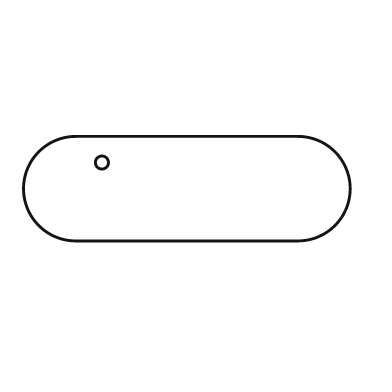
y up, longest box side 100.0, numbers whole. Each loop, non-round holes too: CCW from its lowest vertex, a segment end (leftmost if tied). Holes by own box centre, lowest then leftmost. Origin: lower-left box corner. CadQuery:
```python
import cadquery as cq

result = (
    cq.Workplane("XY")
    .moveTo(16.0, 0.0)
    .lineTo(84.0, 0.0)
    .threePointArc((100.0, 16.0), (84.0, 32.0))
    .lineTo(16.0, 32.0)
    .threePointArc((0.0, 16.0), (16.0, 0.0))
    .close()
    .moveTo(24.0, 24.0)
    .circle(2.0)
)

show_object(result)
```